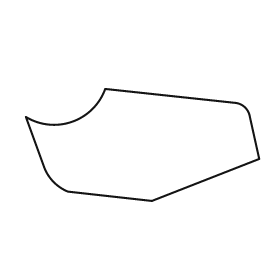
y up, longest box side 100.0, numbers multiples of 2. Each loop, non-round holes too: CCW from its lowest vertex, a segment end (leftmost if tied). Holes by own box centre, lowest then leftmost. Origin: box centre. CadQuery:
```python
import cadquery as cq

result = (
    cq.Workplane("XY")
    .moveTo(4.0, -24.0)
    .lineTo(50.0, -6.0)
    .lineTo(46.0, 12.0)
    .threePointArc((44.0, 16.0), (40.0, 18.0))
    .lineTo(-16.0, 24.0)
    .threePointArc((-30.0, 10.0), (-50.0, 12.0))
    .lineTo(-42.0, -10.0)
    .threePointArc((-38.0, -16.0), (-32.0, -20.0))
    .close()
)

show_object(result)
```